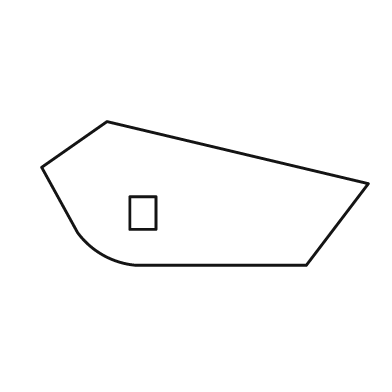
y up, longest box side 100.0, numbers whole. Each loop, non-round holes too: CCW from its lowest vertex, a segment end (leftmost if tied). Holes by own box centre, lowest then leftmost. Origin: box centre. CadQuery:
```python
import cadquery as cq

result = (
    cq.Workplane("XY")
    .moveTo(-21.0, -22.0)
    .lineTo(31.0, -22.0)
    .lineTo(50.0, 3.0)
    .lineTo(-30.0, 22.0)
    .lineTo(-50.0, 8.0)
    .lineTo(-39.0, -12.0)
    .threePointArc((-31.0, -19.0), (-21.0, -22.0))
    .close()
    .moveTo(-23.0, -11.0)
    .lineTo(-15.0, -11.0)
    .lineTo(-15.0, -1.0)
    .lineTo(-23.0, -1.0)
    .close()
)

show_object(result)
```